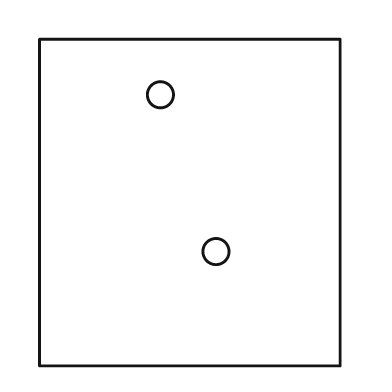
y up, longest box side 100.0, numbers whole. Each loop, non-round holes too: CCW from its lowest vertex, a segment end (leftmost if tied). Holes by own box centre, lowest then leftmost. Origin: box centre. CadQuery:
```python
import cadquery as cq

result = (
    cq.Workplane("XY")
    .moveTo(-46.0, -50.0)
    .lineTo(46.0, -50.0)
    .lineTo(46.0, 50.0)
    .lineTo(-46.0, 50.0)
    .close()
    .moveTo(8.0, -15.0)
    .circle(4.0)
    .moveTo(-9.0, 33.0)
    .circle(4.0)
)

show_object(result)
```